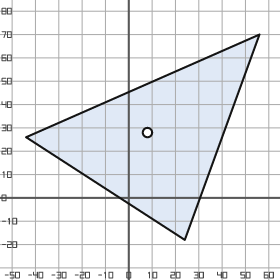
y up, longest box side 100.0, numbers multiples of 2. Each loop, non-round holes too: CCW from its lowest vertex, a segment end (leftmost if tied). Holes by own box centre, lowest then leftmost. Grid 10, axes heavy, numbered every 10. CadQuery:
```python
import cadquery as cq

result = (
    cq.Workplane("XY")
    .moveTo(24.0, -18.0)
    .lineTo(56.0, 70.0)
    .lineTo(-44.0, 26.0)
    .close()
    .moveTo(8.0, 28.0)
    .circle(2.0)
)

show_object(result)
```